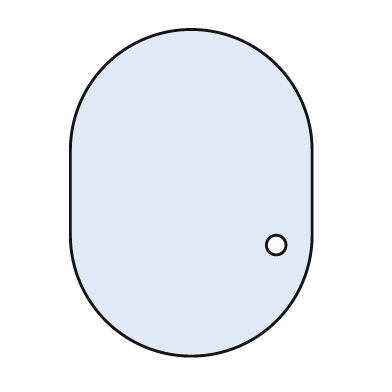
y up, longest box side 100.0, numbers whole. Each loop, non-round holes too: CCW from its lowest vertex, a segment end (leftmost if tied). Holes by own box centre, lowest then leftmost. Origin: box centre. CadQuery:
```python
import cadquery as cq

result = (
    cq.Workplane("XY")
    .moveTo(-37.0, -13.0)
    .threePointArc((0.0, -50.0), (37.0, -13.0))
    .lineTo(37.0, 13.0)
    .threePointArc((0.0, 50.0), (-37.0, 13.0))
    .close()
    .moveTo(26.0, -16.0)
    .circle(3.0)
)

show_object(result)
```